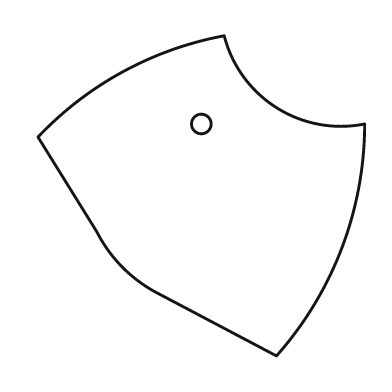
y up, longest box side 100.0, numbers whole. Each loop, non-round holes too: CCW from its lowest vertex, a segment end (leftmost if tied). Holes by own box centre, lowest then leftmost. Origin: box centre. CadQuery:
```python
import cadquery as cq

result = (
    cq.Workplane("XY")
    .moveTo(23.0, -49.0)
    .threePointArc((43.0, -16.0), (50.0, 22.0))
    .threePointArc((23.0, 27.0), (7.0, 49.0))
    .threePointArc((-24.0, 38.0), (-50.0, 18.0))
    .lineTo(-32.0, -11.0)
    .threePointArc((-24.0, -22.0), (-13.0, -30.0))
    .close()
    .moveTo(0.0, 22.0)
    .circle(3.0)
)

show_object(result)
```